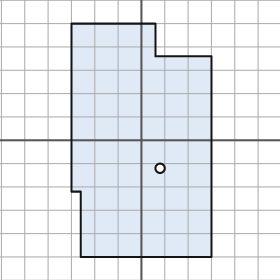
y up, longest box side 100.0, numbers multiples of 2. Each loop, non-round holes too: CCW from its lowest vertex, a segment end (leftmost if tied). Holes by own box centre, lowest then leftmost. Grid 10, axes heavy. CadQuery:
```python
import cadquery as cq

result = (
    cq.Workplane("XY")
    .moveTo(-26.0, -50.0)
    .lineTo(30.0, -50.0)
    .lineTo(30.0, 36.0)
    .lineTo(6.0, 36.0)
    .lineTo(6.0, 50.0)
    .lineTo(-30.0, 50.0)
    .lineTo(-30.0, -22.0)
    .lineTo(-26.0, -22.0)
    .close()
    .moveTo(8.0, -12.0)
    .circle(2.0)
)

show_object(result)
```